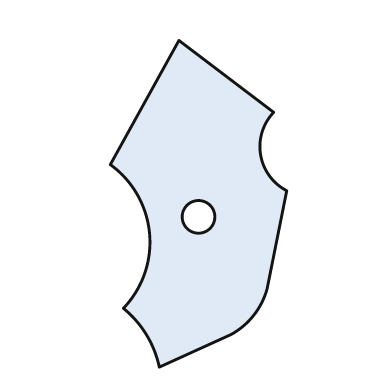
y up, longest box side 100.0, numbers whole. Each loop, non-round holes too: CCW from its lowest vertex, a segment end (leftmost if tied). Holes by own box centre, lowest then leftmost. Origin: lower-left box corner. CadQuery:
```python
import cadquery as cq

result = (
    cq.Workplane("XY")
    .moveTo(15.0, 0.0)
    .lineTo(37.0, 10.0)
    .threePointArc((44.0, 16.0), (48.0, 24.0))
    .lineTo(54.0, 54.0)
    .threePointArc((46.0, 65.0), (50.0, 78.0))
    .lineTo(21.0, 100.0)
    .lineTo(0.0, 62.0)
    .threePointArc((12.0, 41.0), (4.0, 18.0))
    .threePointArc((11.0, 10.0), (15.0, 0.0))
    .close()
    .moveTo(27.0, 46.0)
    .circle(5.0)
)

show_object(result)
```